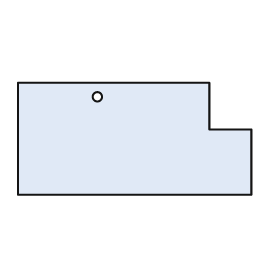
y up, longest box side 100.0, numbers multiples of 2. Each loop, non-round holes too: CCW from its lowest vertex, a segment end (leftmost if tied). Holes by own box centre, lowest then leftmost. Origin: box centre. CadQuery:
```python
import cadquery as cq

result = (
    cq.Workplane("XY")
    .moveTo(-50.0, -24.0)
    .lineTo(50.0, -24.0)
    .lineTo(50.0, 4.0)
    .lineTo(32.0, 4.0)
    .lineTo(32.0, 24.0)
    .lineTo(-50.0, 24.0)
    .close()
    .moveTo(-16.0, 18.0)
    .circle(2.0)
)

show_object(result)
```